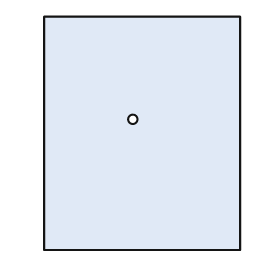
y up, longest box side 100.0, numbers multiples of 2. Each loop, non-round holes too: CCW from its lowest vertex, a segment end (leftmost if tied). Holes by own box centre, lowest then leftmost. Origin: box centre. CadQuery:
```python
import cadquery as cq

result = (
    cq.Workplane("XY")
    .moveTo(-42.0, -50.0)
    .lineTo(42.0, -50.0)
    .lineTo(42.0, 50.0)
    .lineTo(-42.0, 50.0)
    .close()
    .moveTo(-4.0, 6.0)
    .circle(2.0)
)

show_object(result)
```